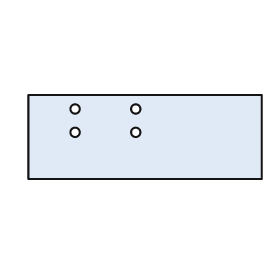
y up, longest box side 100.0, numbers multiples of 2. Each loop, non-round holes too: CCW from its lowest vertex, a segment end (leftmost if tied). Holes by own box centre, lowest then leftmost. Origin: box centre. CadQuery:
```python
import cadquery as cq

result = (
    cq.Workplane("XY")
    .moveTo(-50.0, -18.0)
    .lineTo(50.0, -18.0)
    .lineTo(50.0, 18.0)
    .lineTo(-50.0, 18.0)
    .close()
    .moveTo(-30.0, 2.0)
    .circle(2.0)
    .moveTo(-4.0, 2.0)
    .circle(2.0)
    .moveTo(-30.0, 12.0)
    .circle(2.0)
    .moveTo(-4.0, 12.0)
    .circle(2.0)
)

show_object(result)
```